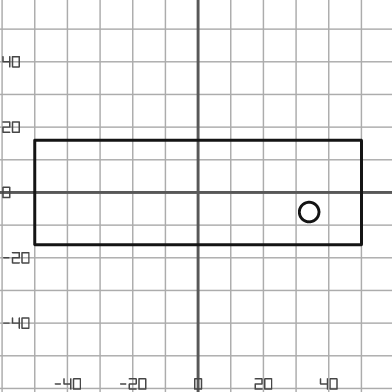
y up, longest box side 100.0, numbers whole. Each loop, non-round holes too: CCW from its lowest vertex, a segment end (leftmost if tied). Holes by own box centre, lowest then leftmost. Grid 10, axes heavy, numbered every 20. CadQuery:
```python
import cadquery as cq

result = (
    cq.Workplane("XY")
    .moveTo(-50.0, -16.0)
    .lineTo(50.0, -16.0)
    .lineTo(50.0, 16.0)
    .lineTo(-50.0, 16.0)
    .close()
    .moveTo(34.0, -6.0)
    .circle(3.0)
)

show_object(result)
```